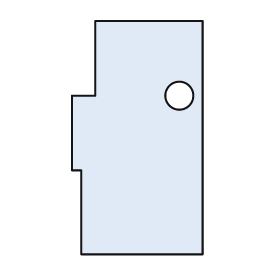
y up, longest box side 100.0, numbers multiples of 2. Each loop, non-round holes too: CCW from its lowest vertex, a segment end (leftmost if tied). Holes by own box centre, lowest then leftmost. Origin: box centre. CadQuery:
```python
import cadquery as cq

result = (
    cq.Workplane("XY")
    .moveTo(-24.0, -50.0)
    .lineTo(28.0, -50.0)
    .lineTo(28.0, 50.0)
    .lineTo(-18.0, 50.0)
    .lineTo(-18.0, 18.0)
    .lineTo(-28.0, 18.0)
    .lineTo(-28.0, -14.0)
    .lineTo(-24.0, -14.0)
    .close()
    .moveTo(18.0, 18.0)
    .circle(6.0)
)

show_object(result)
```